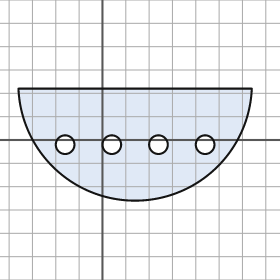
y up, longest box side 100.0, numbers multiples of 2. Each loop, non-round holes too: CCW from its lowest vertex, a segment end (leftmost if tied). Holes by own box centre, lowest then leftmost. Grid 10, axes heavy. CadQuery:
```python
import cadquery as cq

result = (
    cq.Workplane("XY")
    .moveTo(-36.0, 22.0)
    .threePointArc((14.0, -26.0), (64.0, 22.0))
    .close()
    .moveTo(-16.0, -2.0)
    .circle(4.0)
    .moveTo(4.0, -2.0)
    .circle(4.0)
    .moveTo(24.0, -2.0)
    .circle(4.0)
    .moveTo(44.0, -2.0)
    .circle(4.0)
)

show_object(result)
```